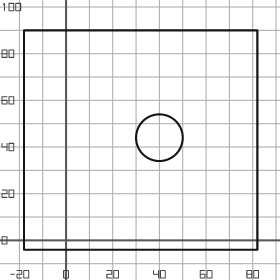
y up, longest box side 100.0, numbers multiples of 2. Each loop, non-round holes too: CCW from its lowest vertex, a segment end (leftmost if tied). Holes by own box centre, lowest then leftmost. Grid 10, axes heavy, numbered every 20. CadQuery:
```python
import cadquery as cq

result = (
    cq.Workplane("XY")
    .moveTo(-18.0, -4.0)
    .lineTo(82.0, -4.0)
    .lineTo(82.0, 90.0)
    .lineTo(-18.0, 90.0)
    .close()
    .moveTo(40.0, 44.0)
    .circle(10.0)
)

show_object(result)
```